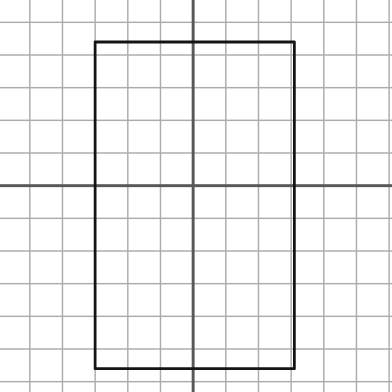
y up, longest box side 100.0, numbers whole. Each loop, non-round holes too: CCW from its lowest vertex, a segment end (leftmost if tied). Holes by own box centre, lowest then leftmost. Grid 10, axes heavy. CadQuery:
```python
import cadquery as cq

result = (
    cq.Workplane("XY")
    .moveTo(-30.0, -56.0)
    .lineTo(31.0, -56.0)
    .lineTo(31.0, 44.0)
    .lineTo(-30.0, 44.0)
    .close()
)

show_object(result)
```